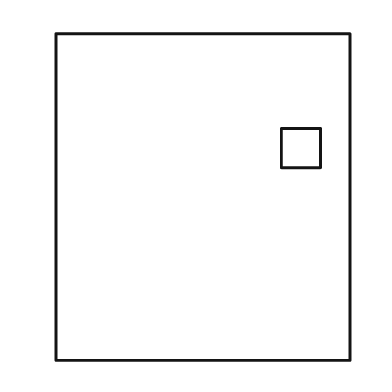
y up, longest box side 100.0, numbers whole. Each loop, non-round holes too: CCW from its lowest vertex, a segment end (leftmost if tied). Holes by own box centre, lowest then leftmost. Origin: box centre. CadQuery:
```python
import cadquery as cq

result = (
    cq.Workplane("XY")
    .moveTo(-45.0, -50.0)
    .lineTo(45.0, -50.0)
    .lineTo(45.0, 50.0)
    .lineTo(-45.0, 50.0)
    .close()
    .moveTo(24.0, 9.0)
    .lineTo(36.0, 9.0)
    .lineTo(36.0, 21.0)
    .lineTo(24.0, 21.0)
    .close()
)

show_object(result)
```